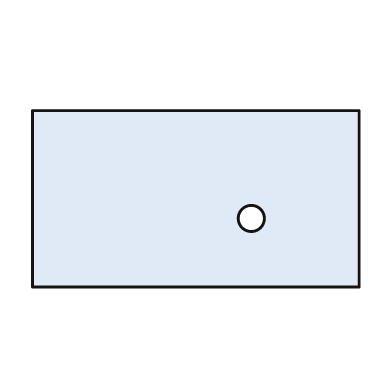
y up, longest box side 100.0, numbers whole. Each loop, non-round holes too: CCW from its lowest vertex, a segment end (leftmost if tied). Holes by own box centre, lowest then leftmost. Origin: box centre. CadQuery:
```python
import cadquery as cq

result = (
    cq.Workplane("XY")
    .moveTo(-50.0, -27.0)
    .lineTo(50.0, -27.0)
    .lineTo(50.0, 27.0)
    .lineTo(-50.0, 27.0)
    .close()
    .moveTo(17.0, -6.0)
    .circle(4.0)
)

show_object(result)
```